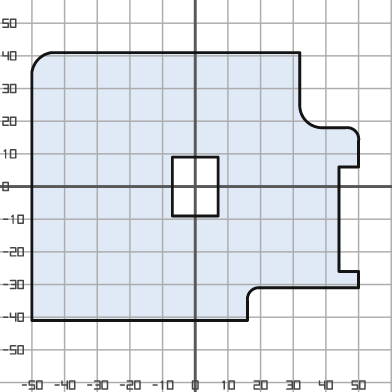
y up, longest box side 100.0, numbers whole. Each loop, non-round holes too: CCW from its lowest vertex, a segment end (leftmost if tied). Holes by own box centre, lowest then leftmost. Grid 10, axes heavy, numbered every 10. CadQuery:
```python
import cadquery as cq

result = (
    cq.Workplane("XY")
    .moveTo(-50.0, -41.0)
    .lineTo(16.0, -41.0)
    .lineTo(16.0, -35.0)
    .threePointArc((17.0, -32.0), (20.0, -31.0))
    .lineTo(50.0, -31.0)
    .lineTo(50.0, -26.0)
    .lineTo(44.0, -26.0)
    .lineTo(44.0, 6.0)
    .lineTo(50.0, 6.0)
    .lineTo(50.0, 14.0)
    .threePointArc((49.0, 17.0), (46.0, 18.0))
    .lineTo(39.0, 18.0)
    .threePointArc((34.0, 20.0), (32.0, 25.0))
    .lineTo(32.0, 41.0)
    .lineTo(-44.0, 41.0)
    .threePointArc((-48.0, 39.0), (-50.0, 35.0))
    .close()
    .moveTo(-7.0, -9.0)
    .lineTo(7.0, -9.0)
    .lineTo(7.0, 9.0)
    .lineTo(-7.0, 9.0)
    .close()
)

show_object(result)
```